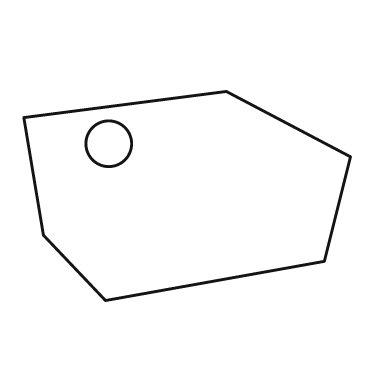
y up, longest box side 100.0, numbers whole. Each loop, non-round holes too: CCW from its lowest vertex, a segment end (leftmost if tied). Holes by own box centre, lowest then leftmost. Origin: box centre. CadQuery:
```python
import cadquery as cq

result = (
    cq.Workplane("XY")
    .moveTo(-25.0, -32.0)
    .lineTo(42.0, -20.0)
    .lineTo(50.0, 12.0)
    .lineTo(12.0, 32.0)
    .lineTo(-50.0, 24.0)
    .lineTo(-44.0, -12.0)
    .close()
    .moveTo(-24.0, 16.0)
    .circle(7.0)
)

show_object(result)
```